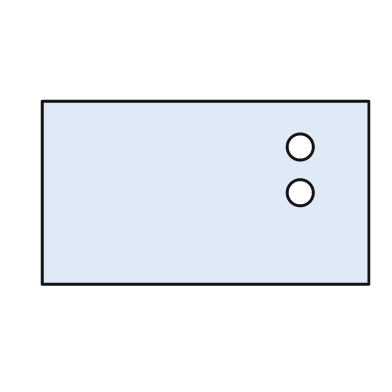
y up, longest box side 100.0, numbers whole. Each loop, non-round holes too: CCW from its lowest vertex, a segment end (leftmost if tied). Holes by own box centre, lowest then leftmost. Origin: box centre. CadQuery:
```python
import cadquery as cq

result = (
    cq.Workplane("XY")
    .moveTo(-50.0, -28.0)
    .lineTo(50.0, -28.0)
    .lineTo(50.0, 28.0)
    .lineTo(-50.0, 28.0)
    .close()
    .moveTo(29.0, 0.0)
    .circle(4.0)
    .moveTo(29.0, 14.0)
    .circle(4.0)
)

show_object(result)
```